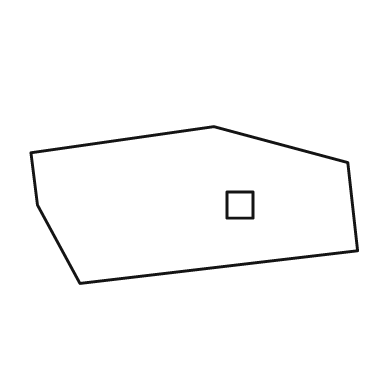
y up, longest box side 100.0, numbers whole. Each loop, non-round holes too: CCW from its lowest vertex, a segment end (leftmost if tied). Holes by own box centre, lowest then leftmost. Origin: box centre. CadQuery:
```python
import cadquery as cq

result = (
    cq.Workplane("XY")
    .moveTo(-35.0, -24.0)
    .lineTo(50.0, -14.0)
    .lineTo(47.0, 13.0)
    .lineTo(6.0, 24.0)
    .lineTo(-50.0, 16.0)
    .lineTo(-48.0, 0.0)
    .close()
    .moveTo(10.0, -4.0)
    .lineTo(18.0, -4.0)
    .lineTo(18.0, 4.0)
    .lineTo(10.0, 4.0)
    .close()
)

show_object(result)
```